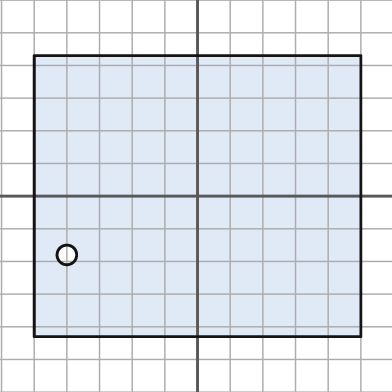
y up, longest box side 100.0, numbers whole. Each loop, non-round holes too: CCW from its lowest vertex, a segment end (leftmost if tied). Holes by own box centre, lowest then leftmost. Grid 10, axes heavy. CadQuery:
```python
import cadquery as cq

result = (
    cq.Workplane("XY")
    .moveTo(-50.0, -43.0)
    .lineTo(50.0, -43.0)
    .lineTo(50.0, 43.0)
    .lineTo(-50.0, 43.0)
    .close()
    .moveTo(-40.0, -18.0)
    .circle(3.0)
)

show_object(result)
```